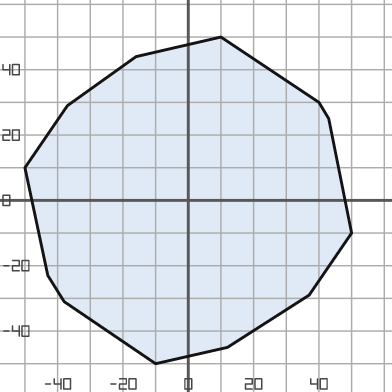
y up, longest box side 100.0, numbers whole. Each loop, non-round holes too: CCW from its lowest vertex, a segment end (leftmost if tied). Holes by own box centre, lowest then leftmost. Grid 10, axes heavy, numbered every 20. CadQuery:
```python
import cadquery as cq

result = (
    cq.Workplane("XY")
    .moveTo(-10.0, -50.0)
    .lineTo(12.0, -45.0)
    .lineTo(37.0, -29.0)
    .lineTo(50.0, -10.0)
    .lineTo(43.0, 25.0)
    .lineTo(40.0, 30.0)
    .lineTo(10.0, 50.0)
    .lineTo(-16.0, 44.0)
    .lineTo(-37.0, 29.0)
    .lineTo(-50.0, 10.0)
    .lineTo(-43.0, -23.0)
    .lineTo(-38.0, -31.0)
    .close()
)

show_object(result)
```